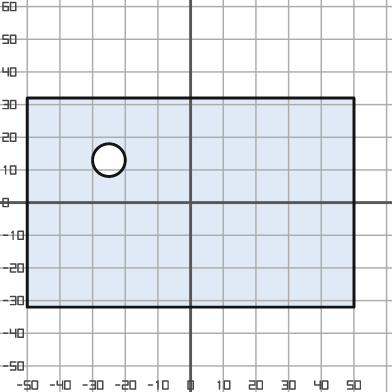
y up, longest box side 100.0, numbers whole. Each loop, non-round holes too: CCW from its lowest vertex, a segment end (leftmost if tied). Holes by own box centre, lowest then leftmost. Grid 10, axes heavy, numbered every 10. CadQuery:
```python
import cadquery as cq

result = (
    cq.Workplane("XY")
    .moveTo(-50.0, -32.0)
    .lineTo(50.0, -32.0)
    .lineTo(50.0, 32.0)
    .lineTo(-50.0, 32.0)
    .close()
    .moveTo(-25.0, 13.0)
    .circle(5.0)
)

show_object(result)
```